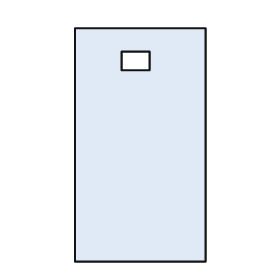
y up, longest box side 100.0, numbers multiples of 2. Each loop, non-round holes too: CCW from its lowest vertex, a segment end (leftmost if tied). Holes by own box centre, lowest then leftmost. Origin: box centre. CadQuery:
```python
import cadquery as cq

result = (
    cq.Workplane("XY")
    .moveTo(-28.0, -50.0)
    .lineTo(28.0, -50.0)
    .lineTo(28.0, 50.0)
    .lineTo(-28.0, 50.0)
    .close()
    .moveTo(-8.0, 32.0)
    .lineTo(4.0, 32.0)
    .lineTo(4.0, 40.0)
    .lineTo(-8.0, 40.0)
    .close()
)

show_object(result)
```